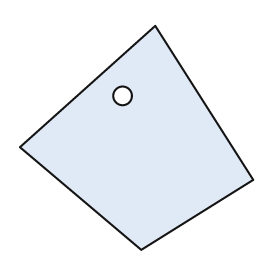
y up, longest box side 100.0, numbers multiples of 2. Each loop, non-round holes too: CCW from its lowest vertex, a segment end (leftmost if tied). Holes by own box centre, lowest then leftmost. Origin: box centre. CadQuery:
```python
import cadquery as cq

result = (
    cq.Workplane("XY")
    .moveTo(2.0, -48.0)
    .lineTo(50.0, -18.0)
    .lineTo(8.0, 48.0)
    .lineTo(-50.0, -4.0)
    .close()
    .moveTo(-6.0, 18.0)
    .circle(4.0)
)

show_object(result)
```